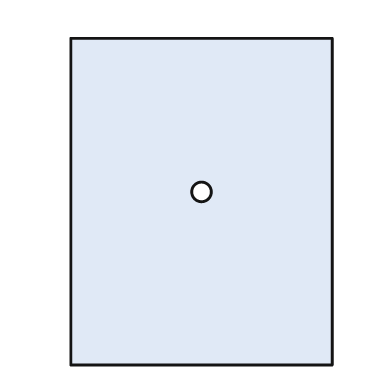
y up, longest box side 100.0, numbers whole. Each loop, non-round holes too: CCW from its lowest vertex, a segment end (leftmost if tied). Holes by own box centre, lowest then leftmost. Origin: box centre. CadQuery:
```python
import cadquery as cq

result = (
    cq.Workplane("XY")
    .moveTo(-40.0, -50.0)
    .lineTo(40.0, -50.0)
    .lineTo(40.0, 50.0)
    .lineTo(-40.0, 50.0)
    .close()
    .moveTo(0.0, 3.0)
    .circle(3.0)
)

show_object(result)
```